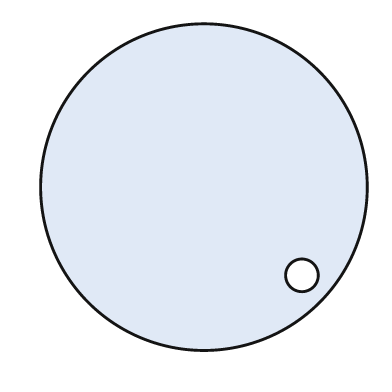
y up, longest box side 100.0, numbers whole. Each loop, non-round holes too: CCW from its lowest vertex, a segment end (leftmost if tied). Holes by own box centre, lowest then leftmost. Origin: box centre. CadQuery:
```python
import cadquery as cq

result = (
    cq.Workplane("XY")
    .moveTo(0.0, 0.0)
    .circle(50.0)
    .moveTo(30.0, -27.0)
    .circle(5.0)
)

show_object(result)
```